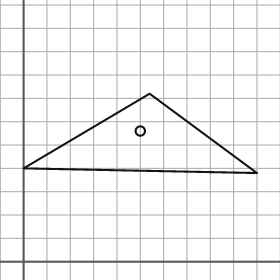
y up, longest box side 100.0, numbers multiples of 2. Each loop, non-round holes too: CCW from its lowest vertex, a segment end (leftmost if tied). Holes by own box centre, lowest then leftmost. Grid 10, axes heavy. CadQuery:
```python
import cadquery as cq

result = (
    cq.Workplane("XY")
    .moveTo(100.0, 38.0)
    .lineTo(54.0, 72.0)
    .lineTo(0.0, 40.0)
    .close()
    .moveTo(50.0, 56.0)
    .circle(2.0)
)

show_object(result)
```